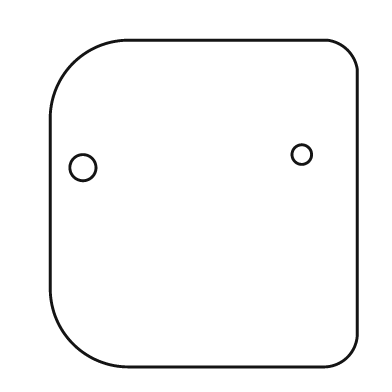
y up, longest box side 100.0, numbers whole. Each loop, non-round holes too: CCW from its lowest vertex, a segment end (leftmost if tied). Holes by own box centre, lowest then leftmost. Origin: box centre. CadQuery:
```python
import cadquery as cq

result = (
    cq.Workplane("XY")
    .moveTo(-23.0, -50.0)
    .lineTo(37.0, -50.0)
    .threePointArc((44.0, -47.0), (47.0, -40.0))
    .lineTo(47.0, 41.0)
    .threePointArc((44.0, 47.0), (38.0, 50.0))
    .lineTo(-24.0, 50.0)
    .threePointArc((-40.0, 43.0), (-47.0, 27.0))
    .lineTo(-47.0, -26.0)
    .threePointArc((-40.0, -43.0), (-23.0, -50.0))
    .close()
    .moveTo(-37.0, 11.0)
    .circle(4.0)
    .moveTo(30.0, 15.0)
    .circle(3.0)
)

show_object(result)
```